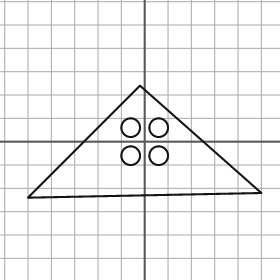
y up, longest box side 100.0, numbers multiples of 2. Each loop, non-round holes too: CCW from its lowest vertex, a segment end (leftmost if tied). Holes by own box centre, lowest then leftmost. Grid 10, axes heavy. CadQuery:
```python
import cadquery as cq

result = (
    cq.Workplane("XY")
    .moveTo(-50.0, -24.0)
    .lineTo(50.0, -22.0)
    .lineTo(-2.0, 24.0)
    .close()
    .moveTo(-6.0, -6.0)
    .circle(4.0)
    .moveTo(6.0, -6.0)
    .circle(4.0)
    .moveTo(-6.0, 6.0)
    .circle(4.0)
    .moveTo(6.0, 6.0)
    .circle(4.0)
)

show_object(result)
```